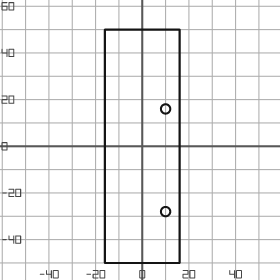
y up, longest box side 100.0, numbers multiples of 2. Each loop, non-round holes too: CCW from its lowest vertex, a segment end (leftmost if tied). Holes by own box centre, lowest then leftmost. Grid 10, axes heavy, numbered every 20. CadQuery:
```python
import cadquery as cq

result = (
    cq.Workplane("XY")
    .moveTo(-16.0, -50.0)
    .lineTo(16.0, -50.0)
    .lineTo(16.0, 50.0)
    .lineTo(-16.0, 50.0)
    .close()
    .moveTo(10.0, -28.0)
    .circle(2.0)
    .moveTo(10.0, 16.0)
    .circle(2.0)
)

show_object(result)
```